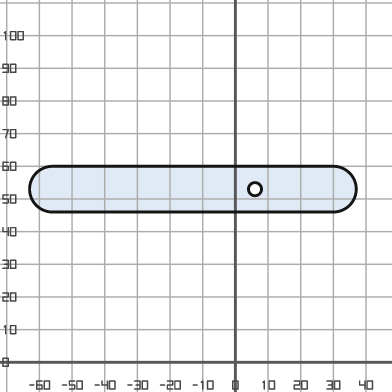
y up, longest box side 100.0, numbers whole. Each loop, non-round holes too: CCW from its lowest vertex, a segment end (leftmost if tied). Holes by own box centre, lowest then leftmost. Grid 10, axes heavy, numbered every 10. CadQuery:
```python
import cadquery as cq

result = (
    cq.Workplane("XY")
    .moveTo(-56.0, 46.0)
    .lineTo(30.0, 46.0)
    .threePointArc((37.0, 53.0), (30.0, 60.0))
    .lineTo(-56.0, 60.0)
    .threePointArc((-63.0, 53.0), (-56.0, 46.0))
    .close()
    .moveTo(6.0, 53.0)
    .circle(2.0)
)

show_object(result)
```